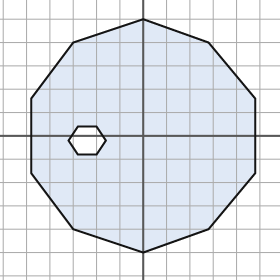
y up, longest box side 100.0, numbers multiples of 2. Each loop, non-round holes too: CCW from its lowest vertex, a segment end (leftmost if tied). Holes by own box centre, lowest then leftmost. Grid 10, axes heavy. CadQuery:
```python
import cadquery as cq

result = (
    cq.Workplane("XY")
    .moveTo(0.0, -50.0)
    .lineTo(28.0, -40.0)
    .lineTo(48.0, -16.0)
    .lineTo(48.0, 16.0)
    .lineTo(28.0, 40.0)
    .lineTo(0.0, 50.0)
    .lineTo(-30.0, 40.0)
    .lineTo(-48.0, 16.0)
    .lineTo(-48.0, -16.0)
    .lineTo(-30.0, -40.0)
    .close()
    .moveTo(-28.0, -8.0)
    .lineTo(-20.0, -8.0)
    .lineTo(-16.0, -2.0)
    .lineTo(-20.0, 4.0)
    .lineTo(-28.0, 4.0)
    .lineTo(-32.0, -2.0)
    .close()
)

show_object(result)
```